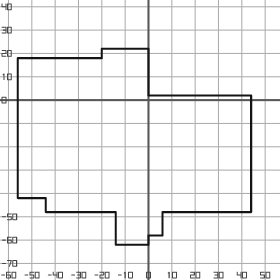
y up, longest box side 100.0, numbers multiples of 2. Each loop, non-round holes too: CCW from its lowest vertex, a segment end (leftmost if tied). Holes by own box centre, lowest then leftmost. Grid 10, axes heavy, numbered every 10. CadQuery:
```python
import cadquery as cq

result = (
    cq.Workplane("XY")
    .moveTo(-14.0, -62.0)
    .lineTo(0.0, -62.0)
    .lineTo(0.0, -58.0)
    .lineTo(6.0, -58.0)
    .lineTo(6.0, -48.0)
    .lineTo(44.0, -48.0)
    .lineTo(44.0, 2.0)
    .lineTo(0.0, 2.0)
    .lineTo(0.0, 22.0)
    .lineTo(-20.0, 22.0)
    .lineTo(-20.0, 18.0)
    .lineTo(-56.0, 18.0)
    .lineTo(-56.0, -42.0)
    .lineTo(-44.0, -42.0)
    .lineTo(-44.0, -48.0)
    .lineTo(-14.0, -48.0)
    .close()
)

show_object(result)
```